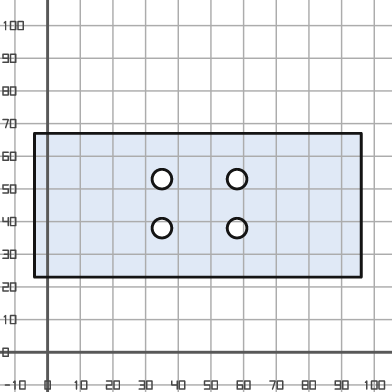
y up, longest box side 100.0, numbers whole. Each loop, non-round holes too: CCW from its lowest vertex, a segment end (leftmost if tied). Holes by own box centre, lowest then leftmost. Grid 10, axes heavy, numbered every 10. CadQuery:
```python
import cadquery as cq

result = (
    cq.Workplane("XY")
    .moveTo(-4.0, 23.0)
    .lineTo(96.0, 23.0)
    .lineTo(96.0, 67.0)
    .lineTo(-4.0, 67.0)
    .close()
    .moveTo(35.0, 38.0)
    .circle(3.0)
    .moveTo(58.0, 38.0)
    .circle(3.0)
    .moveTo(35.0, 53.0)
    .circle(3.0)
    .moveTo(58.0, 53.0)
    .circle(3.0)
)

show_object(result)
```